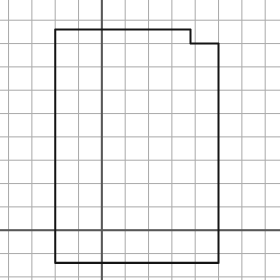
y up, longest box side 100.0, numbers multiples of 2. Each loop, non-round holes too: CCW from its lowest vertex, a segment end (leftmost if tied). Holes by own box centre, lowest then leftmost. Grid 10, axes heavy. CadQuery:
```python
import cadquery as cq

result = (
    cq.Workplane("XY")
    .moveTo(-20.0, -14.0)
    .lineTo(50.0, -14.0)
    .lineTo(50.0, 80.0)
    .lineTo(38.0, 80.0)
    .lineTo(38.0, 86.0)
    .lineTo(-20.0, 86.0)
    .close()
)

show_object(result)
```